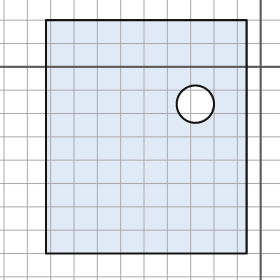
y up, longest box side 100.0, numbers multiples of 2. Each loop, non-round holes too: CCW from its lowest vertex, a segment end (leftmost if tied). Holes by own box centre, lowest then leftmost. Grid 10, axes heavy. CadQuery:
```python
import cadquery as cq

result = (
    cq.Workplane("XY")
    .moveTo(-92.0, -80.0)
    .lineTo(-6.0, -80.0)
    .lineTo(-6.0, 20.0)
    .lineTo(-92.0, 20.0)
    .close()
    .moveTo(-28.0, -16.0)
    .circle(8.0)
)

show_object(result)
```